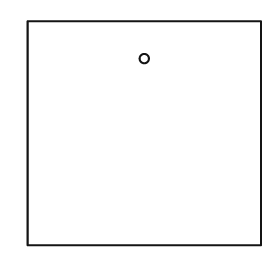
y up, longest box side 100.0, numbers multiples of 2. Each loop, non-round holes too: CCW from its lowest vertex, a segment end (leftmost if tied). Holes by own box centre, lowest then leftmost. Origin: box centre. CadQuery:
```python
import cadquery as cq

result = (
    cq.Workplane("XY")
    .moveTo(-50.0, -48.0)
    .lineTo(50.0, -48.0)
    .lineTo(50.0, 48.0)
    .lineTo(-50.0, 48.0)
    .close()
    .moveTo(0.0, 32.0)
    .circle(2.0)
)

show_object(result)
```